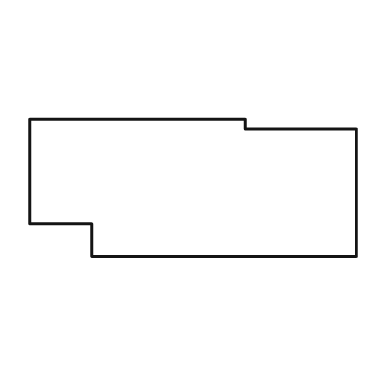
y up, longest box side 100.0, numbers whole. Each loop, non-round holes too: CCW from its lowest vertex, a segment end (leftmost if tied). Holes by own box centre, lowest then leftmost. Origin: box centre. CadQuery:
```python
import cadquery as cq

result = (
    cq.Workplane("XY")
    .moveTo(-31.0, -21.0)
    .lineTo(50.0, -21.0)
    .lineTo(50.0, 18.0)
    .lineTo(16.0, 18.0)
    .lineTo(16.0, 21.0)
    .lineTo(-50.0, 21.0)
    .lineTo(-50.0, -11.0)
    .lineTo(-31.0, -11.0)
    .close()
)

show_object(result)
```